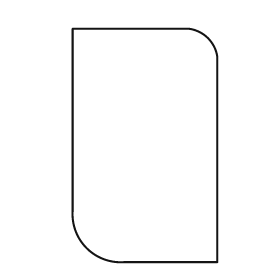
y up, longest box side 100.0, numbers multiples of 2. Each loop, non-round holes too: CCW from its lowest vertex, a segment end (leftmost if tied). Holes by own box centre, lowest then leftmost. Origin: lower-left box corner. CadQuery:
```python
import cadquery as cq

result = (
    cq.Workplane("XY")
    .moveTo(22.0, 0.0)
    .lineTo(62.0, 0.0)
    .lineTo(62.0, 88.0)
    .threePointArc((58.0, 96.0), (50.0, 100.0))
    .lineTo(0.0, 100.0)
    .lineTo(0.0, 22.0)
    .threePointArc((6.0, 6.0), (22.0, 0.0))
    .close()
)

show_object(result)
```